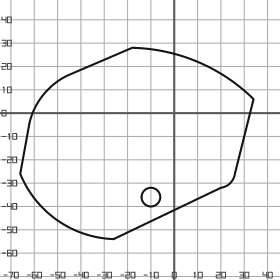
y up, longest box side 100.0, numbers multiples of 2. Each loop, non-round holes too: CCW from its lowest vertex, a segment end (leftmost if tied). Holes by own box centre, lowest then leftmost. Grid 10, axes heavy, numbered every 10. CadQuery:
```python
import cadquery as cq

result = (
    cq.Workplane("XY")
    .moveTo(-26.0, -54.0)
    .lineTo(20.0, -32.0)
    .threePointArc((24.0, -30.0), (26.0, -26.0))
    .lineTo(34.0, 6.0)
    .threePointArc((10.0, 22.0), (-18.0, 28.0))
    .lineTo(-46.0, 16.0)
    .threePointArc((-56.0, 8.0), (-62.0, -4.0))
    .lineTo(-66.0, -26.0)
    .threePointArc((-50.0, -46.0), (-26.0, -54.0))
    .close()
    .moveTo(-10.0, -36.0)
    .circle(4.0)
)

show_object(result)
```